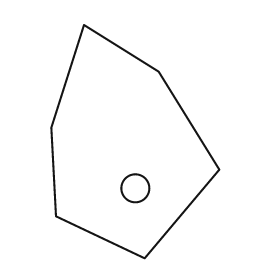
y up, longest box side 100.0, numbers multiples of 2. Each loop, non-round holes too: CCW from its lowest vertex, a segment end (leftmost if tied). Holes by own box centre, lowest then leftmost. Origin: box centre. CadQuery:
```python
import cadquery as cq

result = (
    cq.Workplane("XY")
    .moveTo(4.0, -50.0)
    .lineTo(36.0, -12.0)
    .lineTo(10.0, 30.0)
    .lineTo(-22.0, 50.0)
    .lineTo(-36.0, 6.0)
    .lineTo(-34.0, -32.0)
    .close()
    .moveTo(0.0, -20.0)
    .circle(6.0)
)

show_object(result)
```